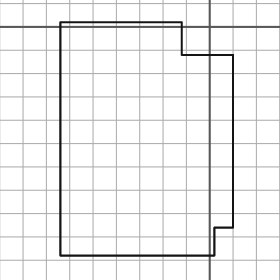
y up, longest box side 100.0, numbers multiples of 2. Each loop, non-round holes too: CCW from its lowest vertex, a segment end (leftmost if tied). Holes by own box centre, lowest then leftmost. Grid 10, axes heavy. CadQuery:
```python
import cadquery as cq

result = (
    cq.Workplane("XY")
    .moveTo(-64.0, -98.0)
    .lineTo(2.0, -98.0)
    .lineTo(2.0, -86.0)
    .lineTo(10.0, -86.0)
    .lineTo(10.0, -12.0)
    .lineTo(-12.0, -12.0)
    .lineTo(-12.0, 2.0)
    .lineTo(-64.0, 2.0)
    .close()
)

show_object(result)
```